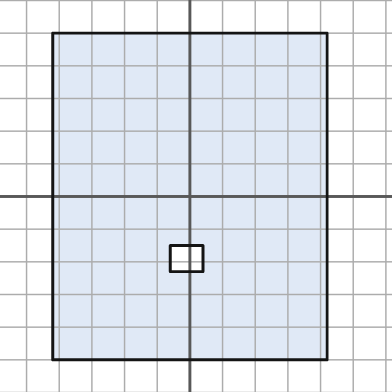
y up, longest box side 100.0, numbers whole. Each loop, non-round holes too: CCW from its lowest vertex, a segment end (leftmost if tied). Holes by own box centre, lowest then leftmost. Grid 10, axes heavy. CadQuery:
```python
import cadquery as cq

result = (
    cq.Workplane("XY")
    .moveTo(-42.0, -50.0)
    .lineTo(42.0, -50.0)
    .lineTo(42.0, 50.0)
    .lineTo(-42.0, 50.0)
    .close()
    .moveTo(-6.0, -23.0)
    .lineTo(4.0, -23.0)
    .lineTo(4.0, -15.0)
    .lineTo(-6.0, -15.0)
    .close()
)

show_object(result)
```